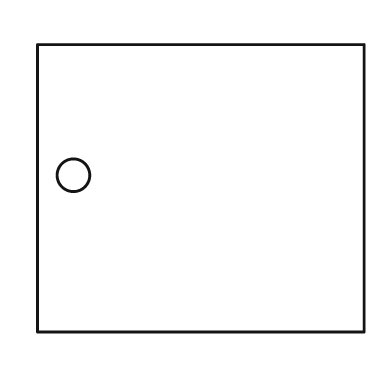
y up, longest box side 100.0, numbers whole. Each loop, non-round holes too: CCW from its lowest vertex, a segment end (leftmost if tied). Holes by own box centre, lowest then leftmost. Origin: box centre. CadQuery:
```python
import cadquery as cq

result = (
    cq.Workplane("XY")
    .moveTo(-50.0, -44.0)
    .lineTo(50.0, -44.0)
    .lineTo(50.0, 44.0)
    .lineTo(-50.0, 44.0)
    .close()
    .moveTo(-39.0, 4.0)
    .circle(5.0)
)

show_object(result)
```